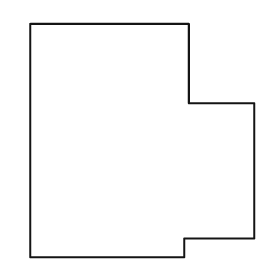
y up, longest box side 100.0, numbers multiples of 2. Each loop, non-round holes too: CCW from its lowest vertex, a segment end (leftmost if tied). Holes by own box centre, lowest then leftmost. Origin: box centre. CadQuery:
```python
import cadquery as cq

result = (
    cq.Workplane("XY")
    .moveTo(-48.0, -50.0)
    .lineTo(18.0, -50.0)
    .lineTo(18.0, -42.0)
    .lineTo(48.0, -42.0)
    .lineTo(48.0, 16.0)
    .lineTo(20.0, 16.0)
    .lineTo(20.0, 50.0)
    .lineTo(-48.0, 50.0)
    .close()
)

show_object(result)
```